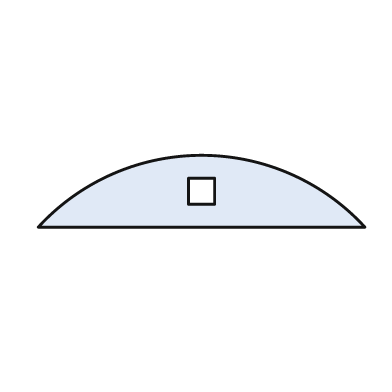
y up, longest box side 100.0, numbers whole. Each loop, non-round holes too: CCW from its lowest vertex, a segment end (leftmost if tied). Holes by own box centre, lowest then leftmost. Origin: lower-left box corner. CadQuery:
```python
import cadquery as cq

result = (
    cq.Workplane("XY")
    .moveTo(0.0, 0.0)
    .lineTo(100.0, 0.0)
    .threePointArc((50.0, 22.0), (0.0, 0.0))
    .close()
    .moveTo(46.0, 7.0)
    .lineTo(54.0, 7.0)
    .lineTo(54.0, 15.0)
    .lineTo(46.0, 15.0)
    .close()
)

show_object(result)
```